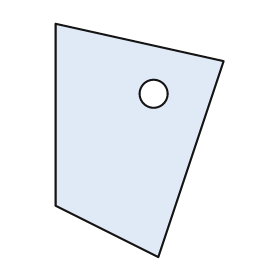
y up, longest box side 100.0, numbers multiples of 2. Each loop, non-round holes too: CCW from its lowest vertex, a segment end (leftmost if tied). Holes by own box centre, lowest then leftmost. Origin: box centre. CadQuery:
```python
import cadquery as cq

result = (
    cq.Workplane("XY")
    .moveTo(8.0, -50.0)
    .lineTo(36.0, 34.0)
    .lineTo(-36.0, 50.0)
    .lineTo(-36.0, -28.0)
    .close()
    .moveTo(6.0, 20.0)
    .circle(6.0)
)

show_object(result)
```